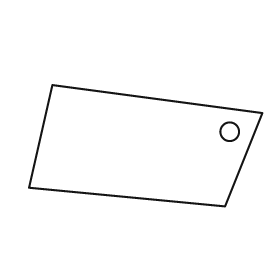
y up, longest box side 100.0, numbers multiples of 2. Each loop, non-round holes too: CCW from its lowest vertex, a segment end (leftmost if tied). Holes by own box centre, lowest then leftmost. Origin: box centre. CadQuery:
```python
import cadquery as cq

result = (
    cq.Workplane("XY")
    .moveTo(34.0, -26.0)
    .lineTo(50.0, 14.0)
    .lineTo(-40.0, 26.0)
    .lineTo(-50.0, -18.0)
    .close()
    .moveTo(36.0, 6.0)
    .circle(4.0)
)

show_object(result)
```